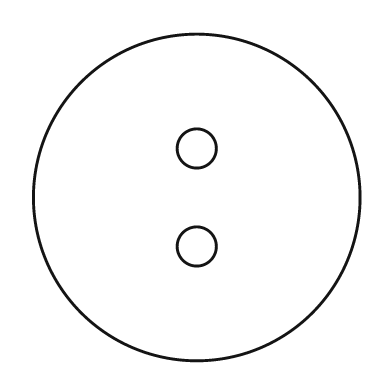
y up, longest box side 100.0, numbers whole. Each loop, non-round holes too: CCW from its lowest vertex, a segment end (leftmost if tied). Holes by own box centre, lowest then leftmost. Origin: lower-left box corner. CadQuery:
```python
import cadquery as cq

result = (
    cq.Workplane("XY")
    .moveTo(50.0, 50.0)
    .circle(50.0)
    .moveTo(50.0, 35.0)
    .circle(6.0)
    .moveTo(50.0, 65.0)
    .circle(6.0)
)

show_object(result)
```